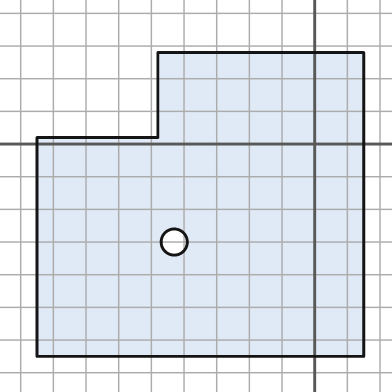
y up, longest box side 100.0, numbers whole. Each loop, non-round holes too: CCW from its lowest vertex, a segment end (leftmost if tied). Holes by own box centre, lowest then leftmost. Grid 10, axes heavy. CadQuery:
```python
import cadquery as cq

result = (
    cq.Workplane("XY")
    .moveTo(-85.0, -65.0)
    .lineTo(15.0, -65.0)
    .lineTo(15.0, 28.0)
    .lineTo(-48.0, 28.0)
    .lineTo(-48.0, 2.0)
    .lineTo(-85.0, 2.0)
    .close()
    .moveTo(-43.0, -30.0)
    .circle(4.0)
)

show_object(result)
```